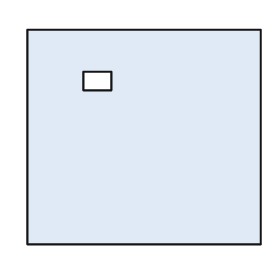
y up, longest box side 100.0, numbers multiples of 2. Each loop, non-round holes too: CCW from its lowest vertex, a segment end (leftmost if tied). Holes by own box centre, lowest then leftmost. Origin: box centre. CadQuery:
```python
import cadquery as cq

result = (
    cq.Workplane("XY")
    .moveTo(-50.0, -46.0)
    .lineTo(50.0, -46.0)
    .lineTo(50.0, 46.0)
    .lineTo(-50.0, 46.0)
    .close()
    .moveTo(-26.0, 20.0)
    .lineTo(-14.0, 20.0)
    .lineTo(-14.0, 28.0)
    .lineTo(-26.0, 28.0)
    .close()
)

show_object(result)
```